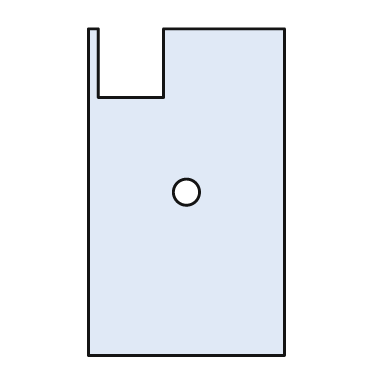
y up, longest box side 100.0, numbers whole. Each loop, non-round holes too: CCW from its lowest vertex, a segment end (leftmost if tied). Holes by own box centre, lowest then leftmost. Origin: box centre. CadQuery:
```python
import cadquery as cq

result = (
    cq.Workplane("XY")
    .moveTo(-30.0, -50.0)
    .lineTo(30.0, -50.0)
    .lineTo(30.0, 50.0)
    .lineTo(-7.0, 50.0)
    .lineTo(-7.0, 29.0)
    .lineTo(-27.0, 29.0)
    .lineTo(-27.0, 50.0)
    .lineTo(-30.0, 50.0)
    .close()
    .moveTo(0.0, 0.0)
    .circle(4.0)
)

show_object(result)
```